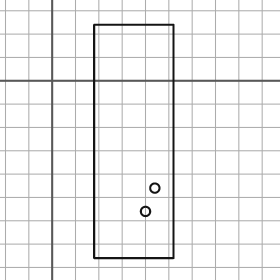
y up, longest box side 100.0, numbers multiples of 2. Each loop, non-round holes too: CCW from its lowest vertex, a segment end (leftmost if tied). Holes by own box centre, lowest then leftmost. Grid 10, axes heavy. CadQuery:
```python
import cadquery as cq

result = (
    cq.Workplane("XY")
    .moveTo(18.0, -76.0)
    .lineTo(52.0, -76.0)
    .lineTo(52.0, 24.0)
    .lineTo(18.0, 24.0)
    .close()
    .moveTo(40.0, -56.0)
    .circle(2.0)
    .moveTo(44.0, -46.0)
    .circle(2.0)
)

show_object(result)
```